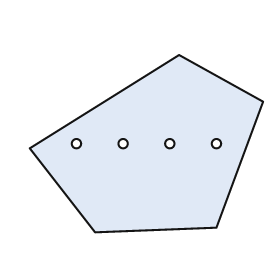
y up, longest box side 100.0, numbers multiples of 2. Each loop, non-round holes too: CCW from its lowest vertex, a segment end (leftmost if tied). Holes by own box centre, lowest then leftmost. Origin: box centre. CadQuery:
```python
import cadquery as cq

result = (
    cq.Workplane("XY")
    .moveTo(-22.0, -38.0)
    .lineTo(30.0, -36.0)
    .lineTo(50.0, 18.0)
    .lineTo(14.0, 38.0)
    .lineTo(-50.0, -2.0)
    .close()
    .moveTo(-30.0, 0.0)
    .circle(2.0)
    .moveTo(-10.0, 0.0)
    .circle(2.0)
    .moveTo(10.0, 0.0)
    .circle(2.0)
    .moveTo(30.0, 0.0)
    .circle(2.0)
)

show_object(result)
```